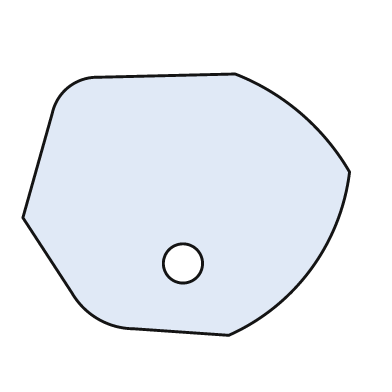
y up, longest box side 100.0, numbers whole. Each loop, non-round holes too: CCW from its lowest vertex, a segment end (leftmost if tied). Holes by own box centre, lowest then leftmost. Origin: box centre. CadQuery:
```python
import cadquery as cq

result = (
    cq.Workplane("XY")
    .moveTo(13.0, -40.0)
    .threePointArc((38.0, -20.0), (50.0, 10.0))
    .threePointArc((35.0, 28.0), (15.0, 40.0))
    .lineTo(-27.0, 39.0)
    .threePointArc((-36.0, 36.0), (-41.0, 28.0))
    .lineTo(-50.0, -4.0)
    .lineTo(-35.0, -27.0)
    .threePointArc((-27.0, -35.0), (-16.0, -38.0))
    .close()
    .moveTo(-1.0, -18.0)
    .circle(6.0)
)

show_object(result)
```